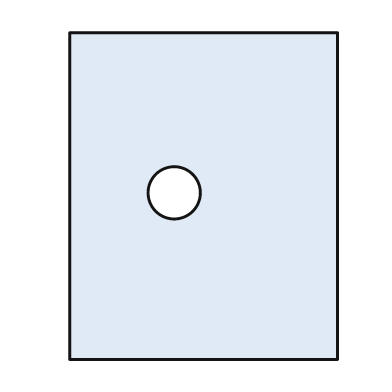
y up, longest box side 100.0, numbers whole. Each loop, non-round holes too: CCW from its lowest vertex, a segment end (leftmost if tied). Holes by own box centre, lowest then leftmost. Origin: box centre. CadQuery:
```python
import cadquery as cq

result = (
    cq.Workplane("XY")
    .moveTo(-41.0, -50.0)
    .lineTo(41.0, -50.0)
    .lineTo(41.0, 50.0)
    .lineTo(-41.0, 50.0)
    .close()
    .moveTo(-9.0, 1.0)
    .circle(8.0)
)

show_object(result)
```